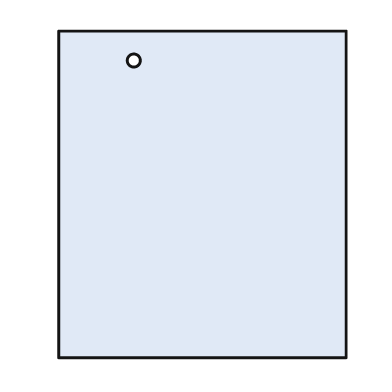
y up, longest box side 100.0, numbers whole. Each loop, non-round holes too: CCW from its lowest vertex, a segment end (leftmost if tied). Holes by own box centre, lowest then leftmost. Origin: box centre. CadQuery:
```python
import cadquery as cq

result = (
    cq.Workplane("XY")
    .moveTo(-44.0, -50.0)
    .lineTo(44.0, -50.0)
    .lineTo(44.0, 50.0)
    .lineTo(-44.0, 50.0)
    .close()
    .moveTo(-21.0, 41.0)
    .circle(2.0)
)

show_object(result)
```